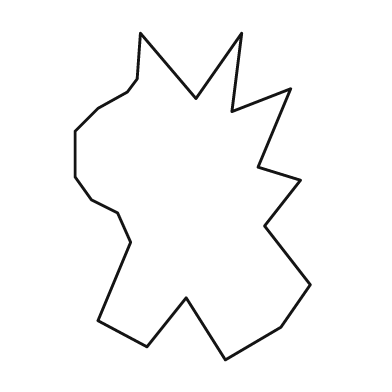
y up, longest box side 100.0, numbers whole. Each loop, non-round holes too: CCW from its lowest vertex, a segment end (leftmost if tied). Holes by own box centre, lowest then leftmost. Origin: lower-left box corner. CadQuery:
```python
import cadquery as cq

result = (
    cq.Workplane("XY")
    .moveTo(46.0, 0.0)
    .lineTo(63.0, 10.0)
    .lineTo(72.0, 23.0)
    .lineTo(58.0, 41.0)
    .lineTo(69.0, 55.0)
    .lineTo(56.0, 59.0)
    .lineTo(66.0, 83.0)
    .lineTo(48.0, 76.0)
    .lineTo(51.0, 100.0)
    .lineTo(37.0, 80.0)
    .lineTo(20.0, 100.0)
    .lineTo(19.0, 86.0)
    .lineTo(16.0, 82.0)
    .lineTo(7.0, 77.0)
    .lineTo(0.0, 70.0)
    .lineTo(0.0, 56.0)
    .lineTo(5.0, 49.0)
    .lineTo(13.0, 45.0)
    .lineTo(17.0, 36.0)
    .lineTo(7.0, 12.0)
    .lineTo(22.0, 4.0)
    .lineTo(34.0, 19.0)
    .close()
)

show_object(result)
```